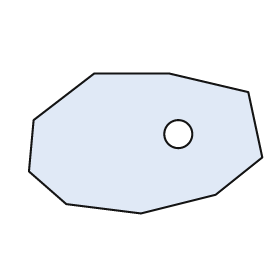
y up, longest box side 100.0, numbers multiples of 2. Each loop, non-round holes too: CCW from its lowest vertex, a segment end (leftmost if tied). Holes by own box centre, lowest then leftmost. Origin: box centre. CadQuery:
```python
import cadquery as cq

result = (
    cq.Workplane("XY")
    .moveTo(-2.0, -30.0)
    .lineTo(30.0, -22.0)
    .lineTo(50.0, -6.0)
    .lineTo(44.0, 22.0)
    .lineTo(10.0, 30.0)
    .lineTo(-22.0, 30.0)
    .lineTo(-48.0, 10.0)
    .lineTo(-50.0, -12.0)
    .lineTo(-34.0, -26.0)
    .close()
    .moveTo(14.0, 4.0)
    .circle(6.0)
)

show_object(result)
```